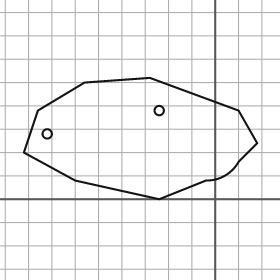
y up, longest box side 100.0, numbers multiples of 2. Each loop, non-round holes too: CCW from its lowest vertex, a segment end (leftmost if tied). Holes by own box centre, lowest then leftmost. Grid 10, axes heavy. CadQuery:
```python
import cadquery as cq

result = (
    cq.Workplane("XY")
    .moveTo(-24.0, 0.0)
    .lineTo(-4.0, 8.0)
    .threePointArc((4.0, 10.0), (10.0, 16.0))
    .lineTo(18.0, 24.0)
    .lineTo(10.0, 38.0)
    .lineTo(-28.0, 52.0)
    .lineTo(-56.0, 50.0)
    .lineTo(-76.0, 38.0)
    .lineTo(-82.0, 20.0)
    .lineTo(-60.0, 8.0)
    .close()
    .moveTo(-72.0, 28.0)
    .circle(2.0)
    .moveTo(-24.0, 38.0)
    .circle(2.0)
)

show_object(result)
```